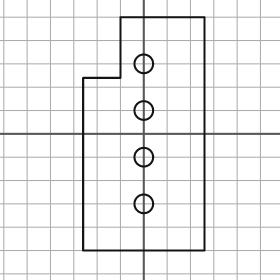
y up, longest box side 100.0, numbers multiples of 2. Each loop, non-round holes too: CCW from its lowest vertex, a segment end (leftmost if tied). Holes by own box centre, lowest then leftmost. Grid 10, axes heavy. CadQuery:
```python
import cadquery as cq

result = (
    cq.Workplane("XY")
    .moveTo(-26.0, -50.0)
    .lineTo(26.0, -50.0)
    .lineTo(26.0, 50.0)
    .lineTo(-10.0, 50.0)
    .lineTo(-10.0, 24.0)
    .lineTo(-26.0, 24.0)
    .close()
    .moveTo(0.0, -30.0)
    .circle(4.0)
    .moveTo(0.0, -10.0)
    .circle(4.0)
    .moveTo(0.0, 10.0)
    .circle(4.0)
    .moveTo(0.0, 30.0)
    .circle(4.0)
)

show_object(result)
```